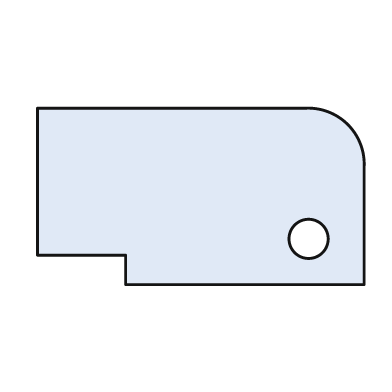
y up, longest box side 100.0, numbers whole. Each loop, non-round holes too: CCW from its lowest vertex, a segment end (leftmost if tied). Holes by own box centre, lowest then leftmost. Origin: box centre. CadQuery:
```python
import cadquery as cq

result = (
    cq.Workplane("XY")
    .moveTo(-23.0, -27.0)
    .lineTo(50.0, -27.0)
    .lineTo(50.0, 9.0)
    .threePointArc((45.0, 22.0), (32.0, 27.0))
    .lineTo(-50.0, 27.0)
    .lineTo(-50.0, -18.0)
    .lineTo(-23.0, -18.0)
    .close()
    .moveTo(33.0, -13.0)
    .circle(6.0)
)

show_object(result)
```